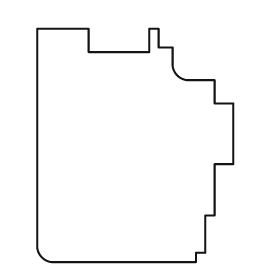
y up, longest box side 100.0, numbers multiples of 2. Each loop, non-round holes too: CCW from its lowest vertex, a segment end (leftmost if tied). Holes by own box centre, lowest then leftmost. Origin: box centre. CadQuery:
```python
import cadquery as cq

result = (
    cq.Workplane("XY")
    .moveTo(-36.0, -50.0)
    .lineTo(26.0, -50.0)
    .lineTo(26.0, -46.0)
    .lineTo(30.0, -46.0)
    .lineTo(30.0, -30.0)
    .lineTo(34.0, -30.0)
    .lineTo(34.0, -8.0)
    .lineTo(42.0, -8.0)
    .lineTo(42.0, 18.0)
    .lineTo(34.0, 18.0)
    .lineTo(34.0, 28.0)
    .lineTo(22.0, 28.0)
    .threePointArc((18.0, 30.0), (16.0, 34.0))
    .lineTo(16.0, 42.0)
    .lineTo(10.0, 42.0)
    .lineTo(10.0, 50.0)
    .lineTo(6.0, 50.0)
    .lineTo(6.0, 40.0)
    .lineTo(-20.0, 40.0)
    .lineTo(-20.0, 50.0)
    .lineTo(-42.0, 50.0)
    .lineTo(-42.0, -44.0)
    .threePointArc((-40.0, -48.0), (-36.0, -50.0))
    .close()
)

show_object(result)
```